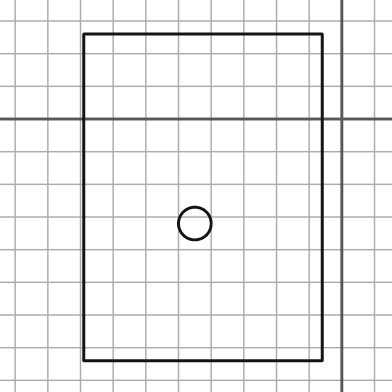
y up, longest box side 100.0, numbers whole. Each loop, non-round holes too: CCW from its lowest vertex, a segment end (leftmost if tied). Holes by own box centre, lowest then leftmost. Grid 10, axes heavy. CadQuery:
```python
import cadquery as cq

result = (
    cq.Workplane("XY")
    .moveTo(-79.0, -74.0)
    .lineTo(-6.0, -74.0)
    .lineTo(-6.0, 26.0)
    .lineTo(-79.0, 26.0)
    .close()
    .moveTo(-45.0, -32.0)
    .circle(5.0)
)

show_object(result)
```